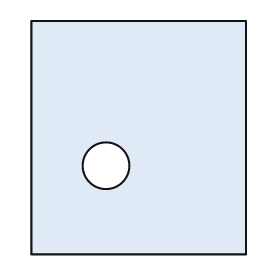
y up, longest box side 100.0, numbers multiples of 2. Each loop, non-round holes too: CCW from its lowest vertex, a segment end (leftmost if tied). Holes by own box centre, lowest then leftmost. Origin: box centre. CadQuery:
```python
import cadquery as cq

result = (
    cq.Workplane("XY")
    .moveTo(-46.0, -50.0)
    .lineTo(46.0, -50.0)
    .lineTo(46.0, 50.0)
    .lineTo(-46.0, 50.0)
    .close()
    .moveTo(-14.0, -12.0)
    .circle(10.0)
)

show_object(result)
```